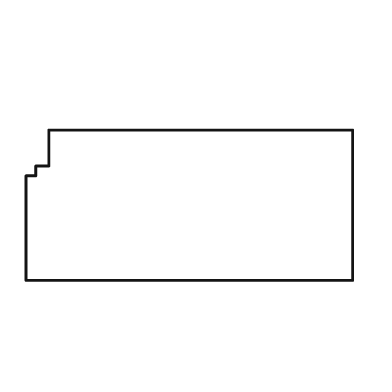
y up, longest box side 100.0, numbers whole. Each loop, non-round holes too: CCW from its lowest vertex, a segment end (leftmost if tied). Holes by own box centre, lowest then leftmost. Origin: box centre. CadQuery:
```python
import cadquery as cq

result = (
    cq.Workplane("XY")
    .moveTo(-50.0, -23.0)
    .lineTo(50.0, -23.0)
    .lineTo(50.0, 23.0)
    .lineTo(-43.0, 23.0)
    .lineTo(-43.0, 12.0)
    .lineTo(-47.0, 12.0)
    .lineTo(-47.0, 9.0)
    .lineTo(-50.0, 9.0)
    .close()
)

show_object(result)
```